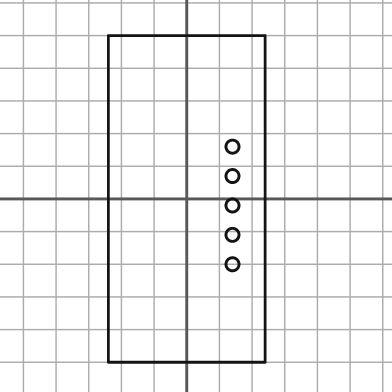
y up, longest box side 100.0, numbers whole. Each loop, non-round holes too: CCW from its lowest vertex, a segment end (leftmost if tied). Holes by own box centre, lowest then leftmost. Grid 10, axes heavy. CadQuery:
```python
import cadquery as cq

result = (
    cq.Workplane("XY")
    .moveTo(-24.0, -50.0)
    .lineTo(24.0, -50.0)
    .lineTo(24.0, 50.0)
    .lineTo(-24.0, 50.0)
    .close()
    .moveTo(14.0, -20.0)
    .circle(2.0)
    .moveTo(14.0, -11.0)
    .circle(2.0)
    .moveTo(14.0, -2.0)
    .circle(2.0)
    .moveTo(14.0, 7.0)
    .circle(2.0)
    .moveTo(14.0, 16.0)
    .circle(2.0)
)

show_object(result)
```